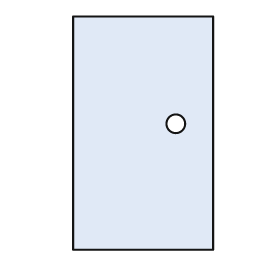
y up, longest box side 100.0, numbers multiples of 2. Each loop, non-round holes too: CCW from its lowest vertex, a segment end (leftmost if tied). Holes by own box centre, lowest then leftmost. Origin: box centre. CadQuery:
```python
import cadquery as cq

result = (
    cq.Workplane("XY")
    .moveTo(-30.0, -50.0)
    .lineTo(30.0, -50.0)
    .lineTo(30.0, 50.0)
    .lineTo(-30.0, 50.0)
    .close()
    .moveTo(14.0, 4.0)
    .circle(4.0)
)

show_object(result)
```